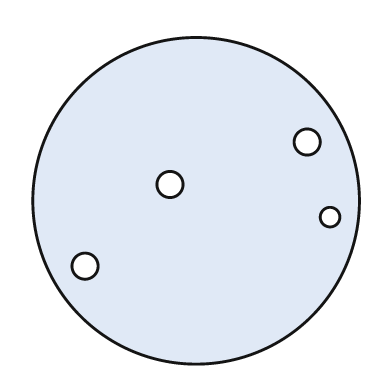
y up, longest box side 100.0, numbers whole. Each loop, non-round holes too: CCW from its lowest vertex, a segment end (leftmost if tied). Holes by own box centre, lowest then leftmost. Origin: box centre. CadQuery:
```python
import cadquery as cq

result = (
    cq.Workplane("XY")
    .moveTo(0.0, 0.0)
    .circle(50.0)
    .moveTo(-34.0, -20.0)
    .circle(4.0)
    .moveTo(41.0, -5.0)
    .circle(3.0)
    .moveTo(-8.0, 5.0)
    .circle(4.0)
    .moveTo(34.0, 18.0)
    .circle(4.0)
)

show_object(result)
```